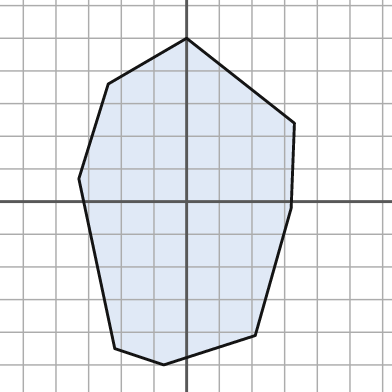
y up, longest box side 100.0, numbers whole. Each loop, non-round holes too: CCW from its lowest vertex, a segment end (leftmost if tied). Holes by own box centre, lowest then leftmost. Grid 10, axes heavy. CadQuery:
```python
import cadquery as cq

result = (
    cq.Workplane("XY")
    .moveTo(-7.0, -50.0)
    .lineTo(21.0, -41.0)
    .lineTo(32.0, -2.0)
    .lineTo(33.0, 24.0)
    .lineTo(0.0, 50.0)
    .lineTo(-24.0, 36.0)
    .lineTo(-33.0, 7.0)
    .lineTo(-22.0, -45.0)
    .close()
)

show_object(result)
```